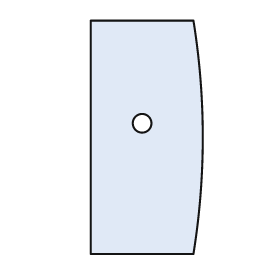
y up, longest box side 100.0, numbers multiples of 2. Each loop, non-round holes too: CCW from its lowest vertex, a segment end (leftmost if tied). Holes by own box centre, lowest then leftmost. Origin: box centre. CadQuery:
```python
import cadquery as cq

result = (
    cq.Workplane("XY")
    .moveTo(-24.0, -50.0)
    .lineTo(20.0, -50.0)
    .threePointArc((24.0, 0.0), (20.0, 50.0))
    .lineTo(-24.0, 50.0)
    .close()
    .moveTo(-2.0, 6.0)
    .circle(4.0)
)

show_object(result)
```